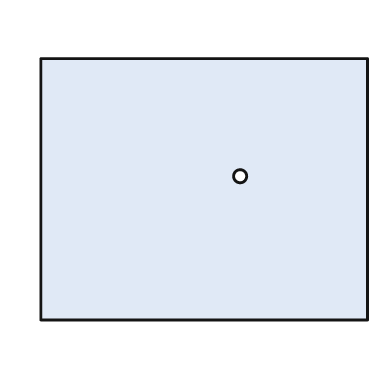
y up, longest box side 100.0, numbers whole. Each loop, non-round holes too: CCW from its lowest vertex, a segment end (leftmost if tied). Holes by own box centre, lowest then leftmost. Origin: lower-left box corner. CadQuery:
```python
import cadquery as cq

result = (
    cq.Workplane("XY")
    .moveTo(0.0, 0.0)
    .lineTo(100.0, 0.0)
    .lineTo(100.0, 80.0)
    .lineTo(0.0, 80.0)
    .close()
    .moveTo(61.0, 44.0)
    .circle(2.0)
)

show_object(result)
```